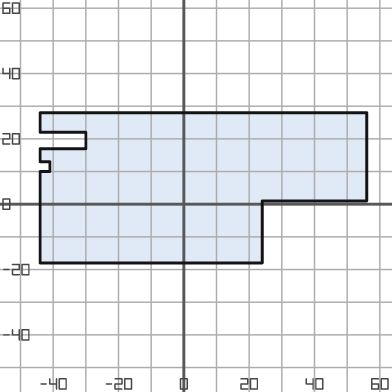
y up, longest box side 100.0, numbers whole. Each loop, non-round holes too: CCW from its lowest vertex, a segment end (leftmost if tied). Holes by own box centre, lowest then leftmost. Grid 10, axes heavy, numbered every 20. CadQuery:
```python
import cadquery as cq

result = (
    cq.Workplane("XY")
    .moveTo(-44.0, -18.0)
    .lineTo(24.0, -18.0)
    .lineTo(24.0, 1.0)
    .lineTo(56.0, 1.0)
    .lineTo(56.0, 28.0)
    .lineTo(-44.0, 28.0)
    .lineTo(-44.0, 22.0)
    .lineTo(-30.0, 22.0)
    .lineTo(-30.0, 17.0)
    .lineTo(-44.0, 17.0)
    .lineTo(-44.0, 13.0)
    .lineTo(-41.0, 13.0)
    .lineTo(-41.0, 10.0)
    .lineTo(-44.0, 10.0)
    .close()
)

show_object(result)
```